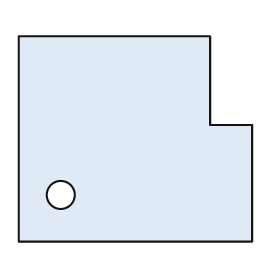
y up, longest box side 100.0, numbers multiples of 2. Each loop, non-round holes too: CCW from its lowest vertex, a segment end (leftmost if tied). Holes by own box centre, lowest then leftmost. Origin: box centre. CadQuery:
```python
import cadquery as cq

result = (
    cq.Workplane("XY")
    .moveTo(-50.0, -44.0)
    .lineTo(50.0, -44.0)
    .lineTo(50.0, 6.0)
    .lineTo(32.0, 6.0)
    .lineTo(32.0, 44.0)
    .lineTo(-50.0, 44.0)
    .close()
    .moveTo(-32.0, -24.0)
    .circle(6.0)
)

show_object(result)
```